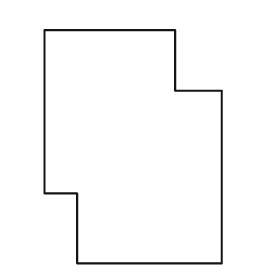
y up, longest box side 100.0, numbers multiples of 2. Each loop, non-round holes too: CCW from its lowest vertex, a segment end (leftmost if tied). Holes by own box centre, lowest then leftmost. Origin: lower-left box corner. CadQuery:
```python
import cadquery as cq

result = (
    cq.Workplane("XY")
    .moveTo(14.0, 0.0)
    .lineTo(76.0, 0.0)
    .lineTo(76.0, 74.0)
    .lineTo(56.0, 74.0)
    .lineTo(56.0, 100.0)
    .lineTo(0.0, 100.0)
    .lineTo(0.0, 30.0)
    .lineTo(14.0, 30.0)
    .close()
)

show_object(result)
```